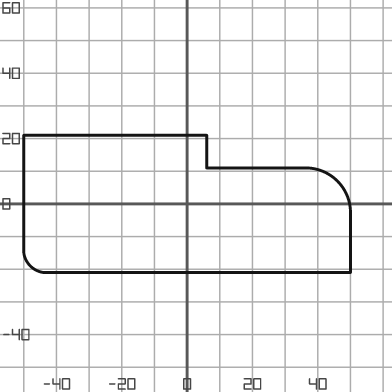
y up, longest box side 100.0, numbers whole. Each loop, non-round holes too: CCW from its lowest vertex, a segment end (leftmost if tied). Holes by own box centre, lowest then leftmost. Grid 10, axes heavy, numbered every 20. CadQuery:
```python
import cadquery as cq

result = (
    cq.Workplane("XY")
    .moveTo(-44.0, -21.0)
    .lineTo(50.0, -21.0)
    .lineTo(50.0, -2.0)
    .threePointArc((46.0, 7.0), (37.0, 11.0))
    .lineTo(6.0, 11.0)
    .lineTo(6.0, 21.0)
    .lineTo(-50.0, 21.0)
    .lineTo(-50.0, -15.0)
    .threePointArc((-48.0, -19.0), (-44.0, -21.0))
    .close()
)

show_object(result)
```